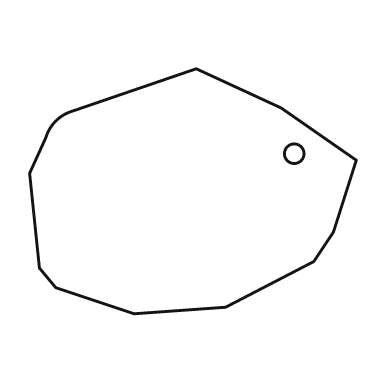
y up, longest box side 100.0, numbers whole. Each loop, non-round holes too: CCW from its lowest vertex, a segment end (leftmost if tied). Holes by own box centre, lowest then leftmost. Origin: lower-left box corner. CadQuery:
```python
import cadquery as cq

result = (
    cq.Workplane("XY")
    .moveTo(32.0, 0.0)
    .lineTo(60.0, 2.0)
    .lineTo(87.0, 16.0)
    .lineTo(93.0, 25.0)
    .lineTo(100.0, 47.0)
    .lineTo(77.0, 63.0)
    .lineTo(51.0, 75.0)
    .lineTo(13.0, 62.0)
    .threePointArc((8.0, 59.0), (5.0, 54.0))
    .lineTo(0.0, 43.0)
    .lineTo(3.0, 14.0)
    .lineTo(8.0, 8.0)
    .close()
    .moveTo(81.0, 49.0)
    .circle(3.0)
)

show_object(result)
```